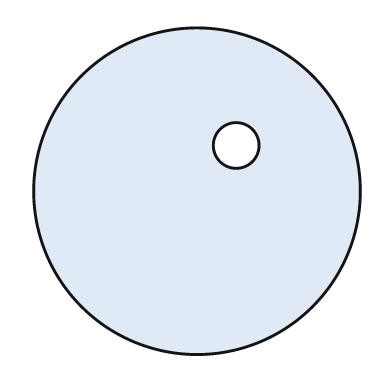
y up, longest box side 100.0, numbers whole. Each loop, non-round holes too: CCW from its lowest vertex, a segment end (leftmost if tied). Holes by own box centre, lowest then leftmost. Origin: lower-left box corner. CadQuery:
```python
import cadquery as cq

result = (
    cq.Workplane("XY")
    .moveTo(50.0, 50.0)
    .circle(50.0)
    .moveTo(62.0, 64.0)
    .circle(7.0)
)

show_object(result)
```